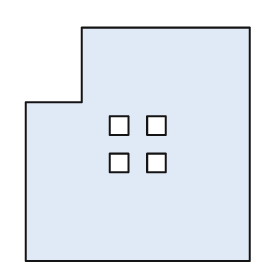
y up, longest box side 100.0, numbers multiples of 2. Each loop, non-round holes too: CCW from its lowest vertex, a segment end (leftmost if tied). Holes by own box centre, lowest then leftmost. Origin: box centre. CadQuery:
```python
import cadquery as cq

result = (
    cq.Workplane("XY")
    .moveTo(-48.0, -50.0)
    .lineTo(48.0, -50.0)
    .lineTo(48.0, 50.0)
    .lineTo(-24.0, 50.0)
    .lineTo(-24.0, 18.0)
    .lineTo(-48.0, 18.0)
    .close()
    .moveTo(-12.0, -12.0)
    .lineTo(-4.0, -12.0)
    .lineTo(-4.0, -4.0)
    .lineTo(-12.0, -4.0)
    .close()
    .moveTo(4.0, -12.0)
    .lineTo(12.0, -12.0)
    .lineTo(12.0, -4.0)
    .lineTo(4.0, -4.0)
    .close()
    .moveTo(-12.0, 4.0)
    .lineTo(-4.0, 4.0)
    .lineTo(-4.0, 12.0)
    .lineTo(-12.0, 12.0)
    .close()
    .moveTo(4.0, 4.0)
    .lineTo(12.0, 4.0)
    .lineTo(12.0, 12.0)
    .lineTo(4.0, 12.0)
    .close()
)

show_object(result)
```